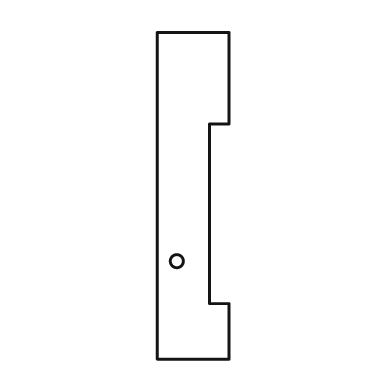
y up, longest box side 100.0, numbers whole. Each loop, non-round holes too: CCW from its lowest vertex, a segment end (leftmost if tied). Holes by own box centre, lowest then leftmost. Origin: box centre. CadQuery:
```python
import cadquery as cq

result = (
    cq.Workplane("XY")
    .moveTo(-11.0, -50.0)
    .lineTo(11.0, -50.0)
    .lineTo(11.0, -33.0)
    .lineTo(5.0, -33.0)
    .lineTo(5.0, 22.0)
    .lineTo(11.0, 22.0)
    .lineTo(11.0, 50.0)
    .lineTo(-11.0, 50.0)
    .close()
    .moveTo(-5.0, -20.0)
    .circle(2.0)
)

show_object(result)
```